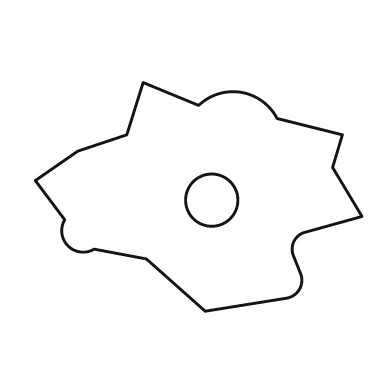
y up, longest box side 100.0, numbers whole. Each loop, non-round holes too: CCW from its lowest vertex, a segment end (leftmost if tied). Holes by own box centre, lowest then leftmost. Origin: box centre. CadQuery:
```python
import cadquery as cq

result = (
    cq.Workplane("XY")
    .moveTo(2.0, -35.0)
    .lineTo(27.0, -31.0)
    .threePointArc((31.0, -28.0), (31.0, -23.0))
    .lineTo(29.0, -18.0)
    .threePointArc((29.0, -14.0), (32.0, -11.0))
    .lineTo(50.0, -6.0)
    .lineTo(41.0, 9.0)
    .lineTo(44.0, 19.0)
    .lineTo(24.0, 24.0)
    .threePointArc((13.0, 32.0), (0.0, 28.0))
    .lineTo(-17.0, 35.0)
    .lineTo(-22.0, 19.0)
    .lineTo(-37.0, 14.0)
    .lineTo(-50.0, 5.0)
    .lineTo(-41.0, -7.0)
    .threePointArc((-40.0, -15.0), (-32.0, -16.0))
    .lineTo(-16.0, -19.0)
    .close()
    .moveTo(4.0, -1.0)
    .circle(8.0)
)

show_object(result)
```